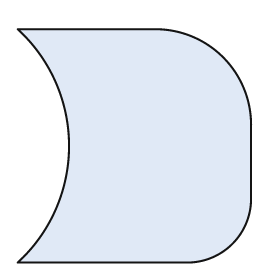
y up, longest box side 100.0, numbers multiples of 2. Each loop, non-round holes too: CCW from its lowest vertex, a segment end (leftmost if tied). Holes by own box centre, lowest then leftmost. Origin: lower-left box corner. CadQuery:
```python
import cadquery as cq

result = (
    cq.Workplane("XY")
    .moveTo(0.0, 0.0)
    .lineTo(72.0, 0.0)
    .threePointArc((92.0, 8.0), (100.0, 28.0))
    .lineTo(100.0, 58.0)
    .threePointArc((88.0, 88.0), (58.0, 100.0))
    .lineTo(0.0, 100.0)
    .threePointArc((22.0, 50.0), (0.0, 0.0))
    .close()
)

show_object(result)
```